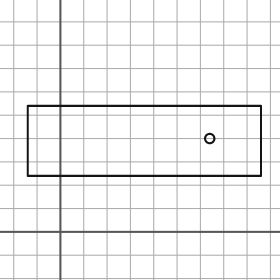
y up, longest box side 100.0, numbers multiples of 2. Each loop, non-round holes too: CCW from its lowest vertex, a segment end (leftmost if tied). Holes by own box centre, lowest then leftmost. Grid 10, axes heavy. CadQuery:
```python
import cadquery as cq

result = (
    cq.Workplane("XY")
    .moveTo(-14.0, 24.0)
    .lineTo(86.0, 24.0)
    .lineTo(86.0, 54.0)
    .lineTo(-14.0, 54.0)
    .close()
    .moveTo(64.0, 40.0)
    .circle(2.0)
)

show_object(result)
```